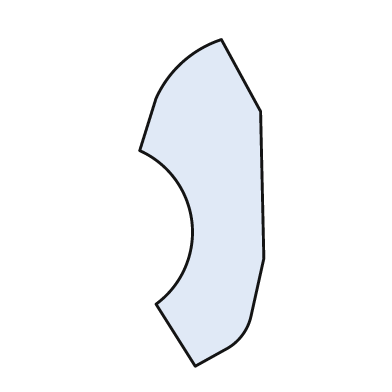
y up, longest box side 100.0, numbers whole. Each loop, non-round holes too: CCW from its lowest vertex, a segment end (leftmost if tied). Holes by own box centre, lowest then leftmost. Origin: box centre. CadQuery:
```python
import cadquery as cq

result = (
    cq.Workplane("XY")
    .moveTo(-2.0, -50.0)
    .lineTo(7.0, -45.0)
    .threePointArc((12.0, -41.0), (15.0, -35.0))
    .lineTo(19.0, -17.0)
    .lineTo(18.0, 28.0)
    .lineTo(6.0, 50.0)
    .threePointArc((-6.0, 43.0), (-14.0, 32.0))
    .lineTo(-19.0, 16.0)
    .threePointArc((-3.0, -6.0), (-14.0, -31.0))
    .close()
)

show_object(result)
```